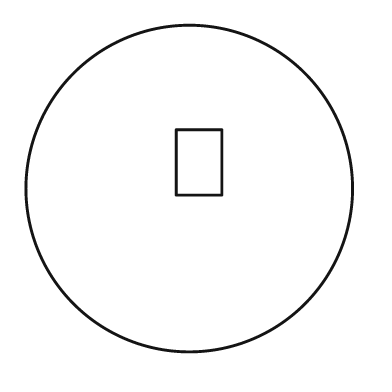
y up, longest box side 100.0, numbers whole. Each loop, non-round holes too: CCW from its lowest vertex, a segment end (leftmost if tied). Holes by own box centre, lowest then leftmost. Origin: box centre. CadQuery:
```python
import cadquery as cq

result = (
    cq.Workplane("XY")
    .moveTo(0.0, 0.0)
    .circle(50.0)
    .moveTo(-4.0, -2.0)
    .lineTo(10.0, -2.0)
    .lineTo(10.0, 18.0)
    .lineTo(-4.0, 18.0)
    .close()
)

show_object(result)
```